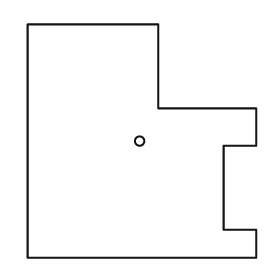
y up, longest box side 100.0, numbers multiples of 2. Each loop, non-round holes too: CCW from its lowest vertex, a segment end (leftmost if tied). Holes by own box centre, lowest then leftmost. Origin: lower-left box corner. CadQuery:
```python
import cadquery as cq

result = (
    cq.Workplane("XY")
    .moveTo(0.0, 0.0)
    .lineTo(98.0, 0.0)
    .lineTo(98.0, 12.0)
    .lineTo(84.0, 12.0)
    .lineTo(84.0, 48.0)
    .lineTo(98.0, 48.0)
    .lineTo(98.0, 64.0)
    .lineTo(56.0, 64.0)
    .lineTo(56.0, 100.0)
    .lineTo(0.0, 100.0)
    .close()
    .moveTo(48.0, 50.0)
    .circle(2.0)
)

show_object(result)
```